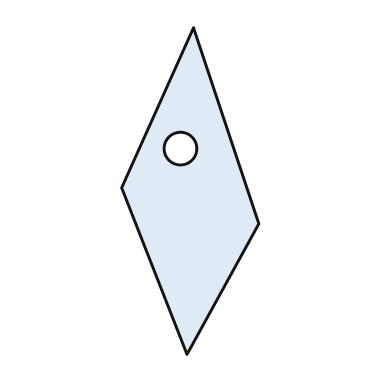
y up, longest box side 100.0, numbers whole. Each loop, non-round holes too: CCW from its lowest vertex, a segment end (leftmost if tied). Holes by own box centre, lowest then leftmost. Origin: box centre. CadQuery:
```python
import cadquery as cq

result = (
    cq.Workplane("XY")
    .moveTo(-1.0, -50.0)
    .lineTo(21.0, -10.0)
    .lineTo(1.0, 50.0)
    .lineTo(-21.0, 1.0)
    .close()
    .moveTo(-3.0, 13.0)
    .circle(5.0)
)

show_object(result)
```